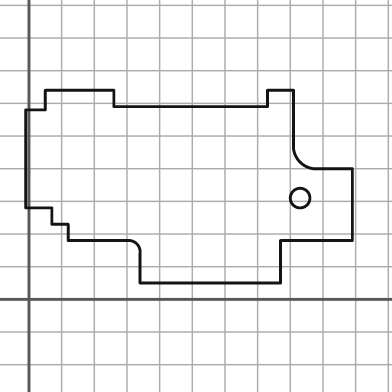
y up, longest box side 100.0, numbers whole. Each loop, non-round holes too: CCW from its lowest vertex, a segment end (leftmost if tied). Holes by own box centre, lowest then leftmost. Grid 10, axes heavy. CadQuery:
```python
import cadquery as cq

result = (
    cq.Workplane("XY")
    .moveTo(34.0, 5.0)
    .lineTo(77.0, 5.0)
    .lineTo(77.0, 18.0)
    .lineTo(99.0, 18.0)
    .lineTo(99.0, 40.0)
    .lineTo(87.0, 40.0)
    .threePointArc((83.0, 42.0), (81.0, 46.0))
    .lineTo(81.0, 64.0)
    .lineTo(73.0, 64.0)
    .lineTo(73.0, 59.0)
    .lineTo(26.0, 59.0)
    .lineTo(26.0, 64.0)
    .lineTo(5.0, 64.0)
    .lineTo(5.0, 58.0)
    .lineTo(-1.0, 58.0)
    .lineTo(-1.0, 28.0)
    .lineTo(7.0, 28.0)
    .lineTo(7.0, 23.0)
    .lineTo(12.0, 23.0)
    .lineTo(12.0, 18.0)
    .lineTo(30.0, 18.0)
    .threePointArc((33.0, 17.0), (34.0, 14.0))
    .close()
    .moveTo(83.0, 31.0)
    .circle(3.0)
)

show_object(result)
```